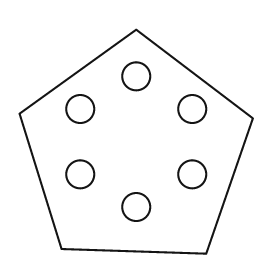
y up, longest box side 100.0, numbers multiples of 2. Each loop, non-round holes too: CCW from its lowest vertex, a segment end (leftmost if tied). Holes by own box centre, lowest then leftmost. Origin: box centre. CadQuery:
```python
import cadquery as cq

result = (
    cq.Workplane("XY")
    .moveTo(30.0, -48.0)
    .lineTo(50.0, 10.0)
    .lineTo(0.0, 48.0)
    .lineTo(-50.0, 12.0)
    .lineTo(-32.0, -46.0)
    .close()
    .moveTo(0.0, -28.0)
    .circle(6.0)
    .moveTo(-24.0, -14.0)
    .circle(6.0)
    .moveTo(24.0, -14.0)
    .circle(6.0)
    .moveTo(-24.0, 14.0)
    .circle(6.0)
    .moveTo(24.0, 14.0)
    .circle(6.0)
    .moveTo(0.0, 28.0)
    .circle(6.0)
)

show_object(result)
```